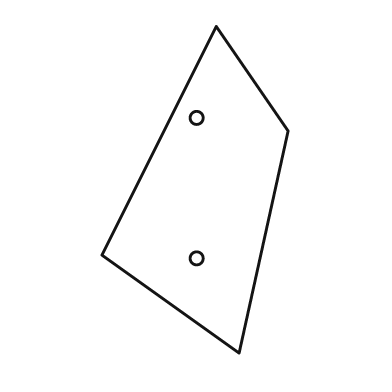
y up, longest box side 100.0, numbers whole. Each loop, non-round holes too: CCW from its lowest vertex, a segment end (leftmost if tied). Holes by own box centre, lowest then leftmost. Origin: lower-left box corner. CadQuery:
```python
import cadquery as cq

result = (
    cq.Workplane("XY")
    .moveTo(42.0, 0.0)
    .lineTo(57.0, 68.0)
    .lineTo(35.0, 100.0)
    .lineTo(0.0, 30.0)
    .close()
    .moveTo(29.0, 29.0)
    .circle(2.0)
    .moveTo(29.0, 72.0)
    .circle(2.0)
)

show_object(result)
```